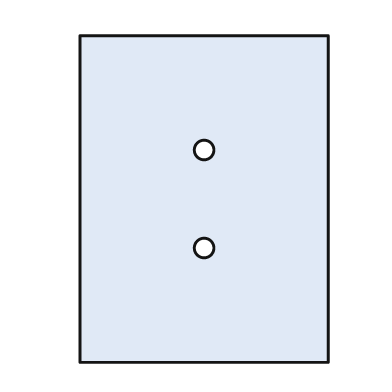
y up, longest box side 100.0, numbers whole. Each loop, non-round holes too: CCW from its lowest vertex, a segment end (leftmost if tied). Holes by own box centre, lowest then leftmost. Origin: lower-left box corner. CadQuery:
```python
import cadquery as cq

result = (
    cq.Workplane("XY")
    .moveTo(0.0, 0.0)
    .lineTo(76.0, 0.0)
    .lineTo(76.0, 100.0)
    .lineTo(0.0, 100.0)
    .close()
    .moveTo(38.0, 35.0)
    .circle(3.0)
    .moveTo(38.0, 65.0)
    .circle(3.0)
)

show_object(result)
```